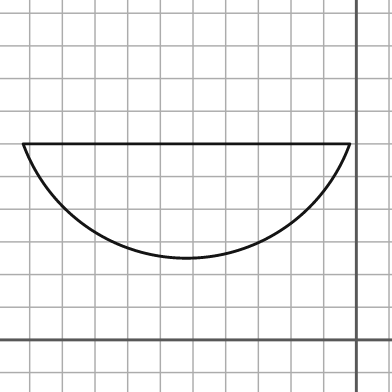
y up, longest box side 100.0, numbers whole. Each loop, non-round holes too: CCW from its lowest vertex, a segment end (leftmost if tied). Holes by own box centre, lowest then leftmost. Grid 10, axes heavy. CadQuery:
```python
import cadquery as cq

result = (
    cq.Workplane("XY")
    .moveTo(-102.0, 60.0)
    .threePointArc((-52.0, 25.0), (-2.0, 60.0))
    .close()
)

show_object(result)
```